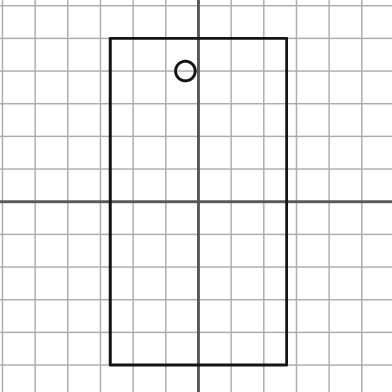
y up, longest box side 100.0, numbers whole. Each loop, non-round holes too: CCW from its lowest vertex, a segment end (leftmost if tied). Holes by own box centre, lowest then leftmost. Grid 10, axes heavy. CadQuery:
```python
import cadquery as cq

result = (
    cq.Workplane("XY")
    .moveTo(-27.0, -50.0)
    .lineTo(27.0, -50.0)
    .lineTo(27.0, 50.0)
    .lineTo(-27.0, 50.0)
    .close()
    .moveTo(-4.0, 40.0)
    .circle(3.0)
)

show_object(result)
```